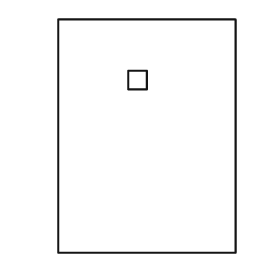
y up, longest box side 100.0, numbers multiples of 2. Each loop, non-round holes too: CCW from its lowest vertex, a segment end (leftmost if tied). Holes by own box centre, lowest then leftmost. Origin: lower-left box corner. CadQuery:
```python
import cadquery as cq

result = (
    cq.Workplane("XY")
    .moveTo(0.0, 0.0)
    .lineTo(76.0, 0.0)
    .lineTo(76.0, 100.0)
    .lineTo(0.0, 100.0)
    .close()
    .moveTo(30.0, 70.0)
    .lineTo(38.0, 70.0)
    .lineTo(38.0, 78.0)
    .lineTo(30.0, 78.0)
    .close()
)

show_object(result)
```